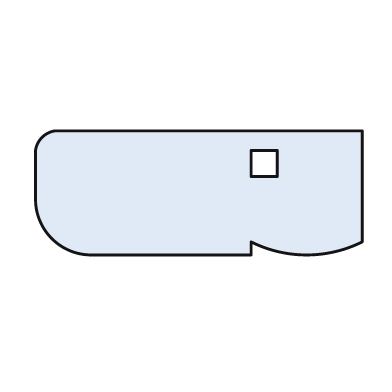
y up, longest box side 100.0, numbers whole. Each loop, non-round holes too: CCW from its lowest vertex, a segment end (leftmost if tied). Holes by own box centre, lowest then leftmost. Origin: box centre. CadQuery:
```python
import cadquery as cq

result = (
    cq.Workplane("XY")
    .moveTo(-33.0, -19.0)
    .lineTo(16.0, -19.0)
    .lineTo(16.0, -15.0)
    .threePointArc((33.0, -19.0), (50.0, -15.0))
    .lineTo(50.0, 19.0)
    .lineTo(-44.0, 19.0)
    .threePointArc((-48.0, 17.0), (-50.0, 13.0))
    .lineTo(-50.0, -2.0)
    .threePointArc((-45.0, -14.0), (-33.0, -19.0))
    .close()
    .moveTo(16.0, 5.0)
    .lineTo(24.0, 5.0)
    .lineTo(24.0, 13.0)
    .lineTo(16.0, 13.0)
    .close()
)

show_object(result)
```